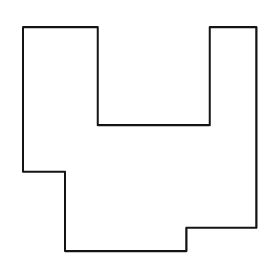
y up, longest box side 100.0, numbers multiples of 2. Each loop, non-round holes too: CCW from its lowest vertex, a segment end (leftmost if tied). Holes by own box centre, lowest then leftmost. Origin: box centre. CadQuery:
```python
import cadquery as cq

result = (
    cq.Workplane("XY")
    .moveTo(-32.0, -48.0)
    .lineTo(20.0, -48.0)
    .lineTo(20.0, -38.0)
    .lineTo(50.0, -38.0)
    .lineTo(50.0, 48.0)
    .lineTo(30.0, 48.0)
    .lineTo(30.0, 6.0)
    .lineTo(-18.0, 6.0)
    .lineTo(-18.0, 48.0)
    .lineTo(-50.0, 48.0)
    .lineTo(-50.0, -14.0)
    .lineTo(-32.0, -14.0)
    .close()
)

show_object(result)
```